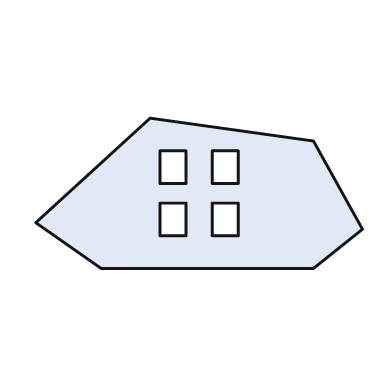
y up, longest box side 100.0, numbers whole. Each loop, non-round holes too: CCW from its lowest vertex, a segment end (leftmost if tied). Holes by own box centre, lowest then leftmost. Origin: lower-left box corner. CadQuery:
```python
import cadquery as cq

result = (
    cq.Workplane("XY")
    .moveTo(20.0, 0.0)
    .lineTo(85.0, 0.0)
    .lineTo(100.0, 12.0)
    .lineTo(85.0, 39.0)
    .lineTo(35.0, 46.0)
    .lineTo(0.0, 14.0)
    .close()
    .moveTo(38.0, 10.0)
    .lineTo(46.0, 10.0)
    .lineTo(46.0, 20.0)
    .lineTo(38.0, 20.0)
    .close()
    .moveTo(54.0, 10.0)
    .lineTo(62.0, 10.0)
    .lineTo(62.0, 20.0)
    .lineTo(54.0, 20.0)
    .close()
    .moveTo(38.0, 26.0)
    .lineTo(46.0, 26.0)
    .lineTo(46.0, 36.0)
    .lineTo(38.0, 36.0)
    .close()
    .moveTo(54.0, 26.0)
    .lineTo(62.0, 26.0)
    .lineTo(62.0, 36.0)
    .lineTo(54.0, 36.0)
    .close()
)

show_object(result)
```